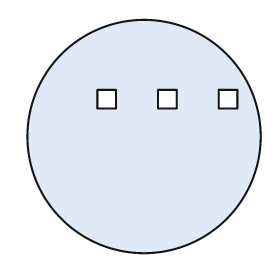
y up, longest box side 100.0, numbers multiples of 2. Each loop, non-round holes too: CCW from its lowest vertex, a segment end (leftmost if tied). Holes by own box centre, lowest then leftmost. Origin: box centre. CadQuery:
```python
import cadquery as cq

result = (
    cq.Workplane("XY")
    .moveTo(0.0, 0.0)
    .circle(50.0)
    .moveTo(-20.0, 12.0)
    .lineTo(-12.0, 12.0)
    .lineTo(-12.0, 20.0)
    .lineTo(-20.0, 20.0)
    .close()
    .moveTo(6.0, 12.0)
    .lineTo(14.0, 12.0)
    .lineTo(14.0, 20.0)
    .lineTo(6.0, 20.0)
    .close()
    .moveTo(32.0, 12.0)
    .lineTo(40.0, 12.0)
    .lineTo(40.0, 20.0)
    .lineTo(32.0, 20.0)
    .close()
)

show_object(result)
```